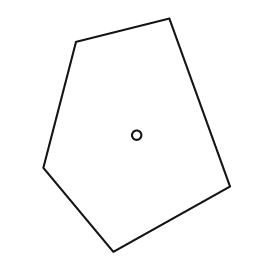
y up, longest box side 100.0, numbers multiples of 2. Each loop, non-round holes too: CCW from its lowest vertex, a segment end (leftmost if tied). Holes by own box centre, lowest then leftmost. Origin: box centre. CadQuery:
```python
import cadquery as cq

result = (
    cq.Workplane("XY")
    .moveTo(-10.0, -50.0)
    .lineTo(40.0, -22.0)
    .lineTo(14.0, 50.0)
    .lineTo(-26.0, 40.0)
    .lineTo(-40.0, -14.0)
    .close()
    .moveTo(0.0, 0.0)
    .circle(2.0)
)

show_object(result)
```